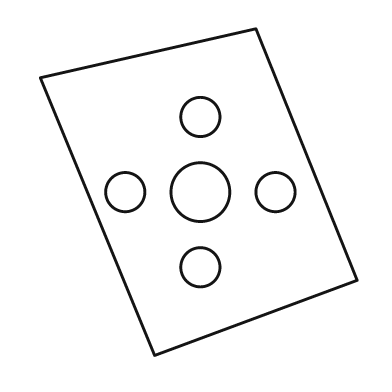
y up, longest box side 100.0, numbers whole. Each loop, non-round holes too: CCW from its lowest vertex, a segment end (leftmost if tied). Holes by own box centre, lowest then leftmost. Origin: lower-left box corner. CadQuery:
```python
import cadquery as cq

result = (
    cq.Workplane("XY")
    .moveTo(35.0, 0.0)
    .lineTo(97.0, 23.0)
    .lineTo(66.0, 100.0)
    .lineTo(0.0, 85.0)
    .close()
    .moveTo(49.0, 27.0)
    .circle(6.0)
    .moveTo(26.0, 50.0)
    .circle(6.0)
    .moveTo(49.0, 50.0)
    .circle(9.0)
    .moveTo(72.0, 50.0)
    .circle(6.0)
    .moveTo(49.0, 73.0)
    .circle(6.0)
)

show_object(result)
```